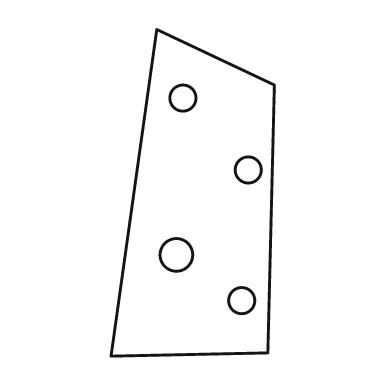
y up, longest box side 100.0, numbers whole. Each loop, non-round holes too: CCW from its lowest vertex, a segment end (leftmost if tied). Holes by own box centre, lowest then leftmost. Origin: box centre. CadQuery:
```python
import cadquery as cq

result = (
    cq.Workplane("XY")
    .moveTo(-25.0, -50.0)
    .lineTo(23.0, -49.0)
    .lineTo(25.0, 33.0)
    .lineTo(-11.0, 50.0)
    .close()
    .moveTo(15.0, -33.0)
    .circle(4.0)
    .moveTo(-5.0, -19.0)
    .circle(5.0)
    .moveTo(17.0, 7.0)
    .circle(4.0)
    .moveTo(-3.0, 29.0)
    .circle(4.0)
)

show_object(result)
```